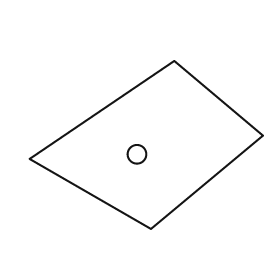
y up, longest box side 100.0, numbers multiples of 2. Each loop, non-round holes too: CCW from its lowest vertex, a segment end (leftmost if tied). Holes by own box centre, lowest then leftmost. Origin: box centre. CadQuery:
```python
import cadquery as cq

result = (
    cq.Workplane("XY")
    .moveTo(2.0, -36.0)
    .lineTo(50.0, 4.0)
    .lineTo(12.0, 36.0)
    .lineTo(-50.0, -6.0)
    .close()
    .moveTo(-4.0, -4.0)
    .circle(4.0)
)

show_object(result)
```